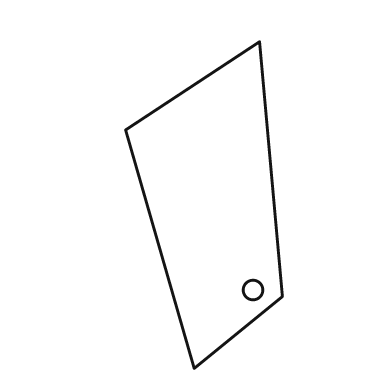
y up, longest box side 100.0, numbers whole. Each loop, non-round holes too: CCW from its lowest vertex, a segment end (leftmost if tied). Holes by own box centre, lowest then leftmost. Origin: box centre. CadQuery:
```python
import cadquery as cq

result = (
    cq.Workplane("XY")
    .moveTo(-3.0, -50.0)
    .lineTo(24.0, -28.0)
    .lineTo(17.0, 50.0)
    .lineTo(-24.0, 23.0)
    .close()
    .moveTo(15.0, -26.0)
    .circle(3.0)
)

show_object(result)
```